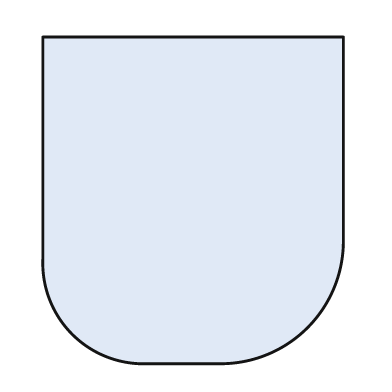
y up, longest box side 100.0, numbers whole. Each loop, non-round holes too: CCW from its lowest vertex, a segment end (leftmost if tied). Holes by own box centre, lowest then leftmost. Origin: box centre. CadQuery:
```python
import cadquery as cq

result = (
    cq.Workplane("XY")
    .moveTo(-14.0, -50.0)
    .lineTo(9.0, -50.0)
    .threePointArc((35.0, -39.0), (46.0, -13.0))
    .lineTo(46.0, 50.0)
    .lineTo(-46.0, 50.0)
    .lineTo(-46.0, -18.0)
    .threePointArc((-37.0, -41.0), (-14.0, -50.0))
    .close()
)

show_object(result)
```